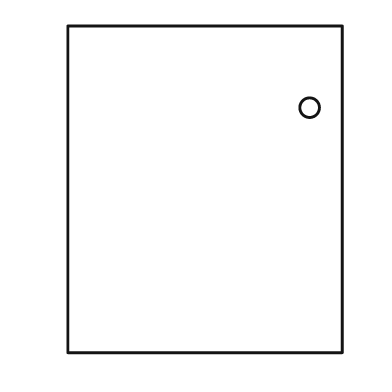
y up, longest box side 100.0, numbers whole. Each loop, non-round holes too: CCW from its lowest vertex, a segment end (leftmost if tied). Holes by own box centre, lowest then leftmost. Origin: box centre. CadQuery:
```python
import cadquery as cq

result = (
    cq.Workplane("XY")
    .moveTo(-42.0, -50.0)
    .lineTo(42.0, -50.0)
    .lineTo(42.0, 50.0)
    .lineTo(-42.0, 50.0)
    .close()
    .moveTo(32.0, 25.0)
    .circle(3.0)
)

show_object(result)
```